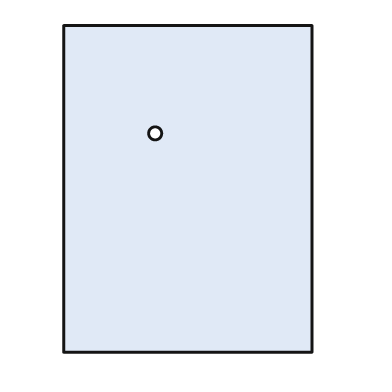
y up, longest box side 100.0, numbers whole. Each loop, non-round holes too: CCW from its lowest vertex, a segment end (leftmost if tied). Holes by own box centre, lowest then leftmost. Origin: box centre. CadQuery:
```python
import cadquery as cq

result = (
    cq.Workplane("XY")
    .moveTo(-38.0, -50.0)
    .lineTo(38.0, -50.0)
    .lineTo(38.0, 50.0)
    .lineTo(-38.0, 50.0)
    .close()
    .moveTo(-10.0, 17.0)
    .circle(2.0)
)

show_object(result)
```